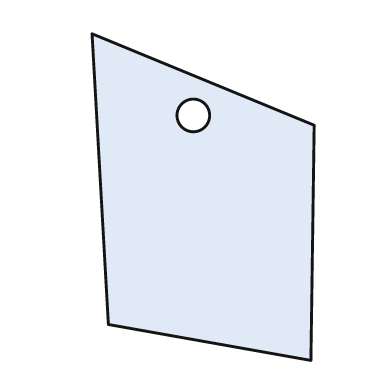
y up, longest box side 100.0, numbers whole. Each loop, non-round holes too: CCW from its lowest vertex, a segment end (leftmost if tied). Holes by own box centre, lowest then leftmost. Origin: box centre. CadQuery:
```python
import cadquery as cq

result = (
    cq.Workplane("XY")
    .moveTo(33.0, -50.0)
    .lineTo(34.0, 22.0)
    .lineTo(-34.0, 50.0)
    .lineTo(-29.0, -39.0)
    .close()
    .moveTo(-3.0, 25.0)
    .circle(5.0)
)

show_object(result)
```